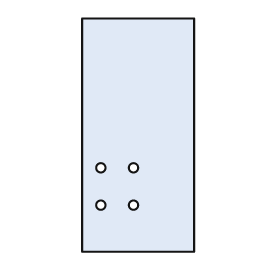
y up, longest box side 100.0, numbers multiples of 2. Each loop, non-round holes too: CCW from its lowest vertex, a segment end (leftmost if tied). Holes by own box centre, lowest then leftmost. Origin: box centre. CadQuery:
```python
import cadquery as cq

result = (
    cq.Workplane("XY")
    .moveTo(-24.0, -50.0)
    .lineTo(24.0, -50.0)
    .lineTo(24.0, 50.0)
    .lineTo(-24.0, 50.0)
    .close()
    .moveTo(-16.0, -30.0)
    .circle(2.0)
    .moveTo(-2.0, -30.0)
    .circle(2.0)
    .moveTo(-16.0, -14.0)
    .circle(2.0)
    .moveTo(-2.0, -14.0)
    .circle(2.0)
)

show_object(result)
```